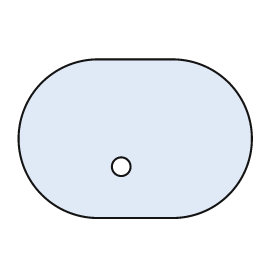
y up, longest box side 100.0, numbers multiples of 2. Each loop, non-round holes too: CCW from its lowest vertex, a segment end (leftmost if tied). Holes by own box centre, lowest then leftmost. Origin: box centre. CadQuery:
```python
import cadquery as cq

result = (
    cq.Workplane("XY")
    .moveTo(-16.0, -34.0)
    .lineTo(16.0, -34.0)
    .threePointArc((50.0, 0.0), (16.0, 34.0))
    .lineTo(-16.0, 34.0)
    .threePointArc((-50.0, 0.0), (-16.0, -34.0))
    .close()
    .moveTo(-6.0, -12.0)
    .circle(4.0)
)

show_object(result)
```